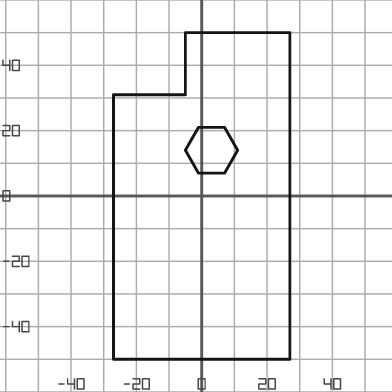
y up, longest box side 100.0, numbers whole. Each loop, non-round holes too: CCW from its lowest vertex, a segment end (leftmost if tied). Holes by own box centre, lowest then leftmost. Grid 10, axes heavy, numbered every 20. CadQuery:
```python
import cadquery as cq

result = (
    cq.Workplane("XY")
    .moveTo(-27.0, -50.0)
    .lineTo(27.0, -50.0)
    .lineTo(27.0, 50.0)
    .lineTo(-5.0, 50.0)
    .lineTo(-5.0, 31.0)
    .lineTo(-27.0, 31.0)
    .close()
    .moveTo(-1.0, 7.0)
    .lineTo(7.0, 7.0)
    .lineTo(11.0, 14.0)
    .lineTo(7.0, 21.0)
    .lineTo(-1.0, 21.0)
    .lineTo(-5.0, 14.0)
    .close()
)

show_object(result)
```